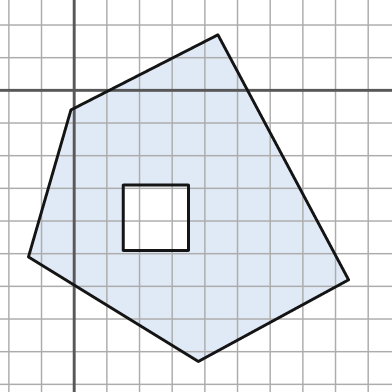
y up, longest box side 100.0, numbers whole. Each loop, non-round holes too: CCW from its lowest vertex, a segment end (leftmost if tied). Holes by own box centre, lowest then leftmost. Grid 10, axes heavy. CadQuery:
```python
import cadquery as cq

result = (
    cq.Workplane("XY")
    .moveTo(38.0, -83.0)
    .lineTo(84.0, -58.0)
    .lineTo(44.0, 17.0)
    .lineTo(-1.0, -6.0)
    .lineTo(-14.0, -51.0)
    .close()
    .moveTo(15.0, -49.0)
    .lineTo(35.0, -49.0)
    .lineTo(35.0, -29.0)
    .lineTo(15.0, -29.0)
    .close()
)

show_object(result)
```